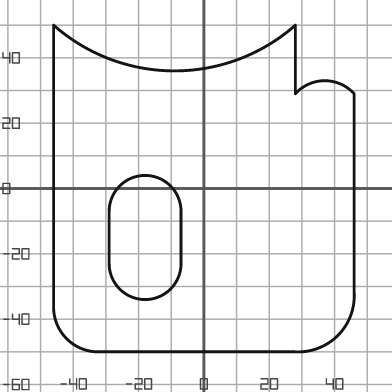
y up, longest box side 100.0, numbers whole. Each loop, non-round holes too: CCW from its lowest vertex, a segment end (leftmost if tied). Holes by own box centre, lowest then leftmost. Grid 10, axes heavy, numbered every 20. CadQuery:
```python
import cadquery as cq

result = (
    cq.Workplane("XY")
    .moveTo(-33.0, -50.0)
    .lineTo(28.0, -50.0)
    .threePointArc((41.0, -45.0), (46.0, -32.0))
    .lineTo(46.0, 29.0)
    .threePointArc((37.0, 33.0), (28.0, 29.0))
    .lineTo(28.0, 50.0)
    .threePointArc((-9.0, 36.0), (-46.0, 50.0))
    .lineTo(-46.0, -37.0)
    .threePointArc((-42.0, -46.0), (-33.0, -50.0))
    .close()
    .moveTo(-29.0, -23.0)
    .threePointArc((-18.0, -34.0), (-7.0, -23.0))
    .lineTo(-7.0, -7.0)
    .threePointArc((-18.0, 4.0), (-29.0, -7.0))
    .close()
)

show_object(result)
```